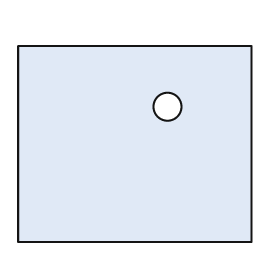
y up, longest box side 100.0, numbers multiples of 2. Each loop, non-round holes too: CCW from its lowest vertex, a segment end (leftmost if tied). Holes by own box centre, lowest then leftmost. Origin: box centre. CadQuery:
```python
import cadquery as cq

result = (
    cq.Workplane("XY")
    .moveTo(-50.0, -42.0)
    .lineTo(50.0, -42.0)
    .lineTo(50.0, 42.0)
    .lineTo(-50.0, 42.0)
    .close()
    .moveTo(14.0, 16.0)
    .circle(6.0)
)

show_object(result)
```